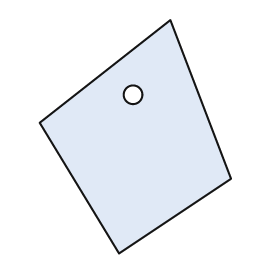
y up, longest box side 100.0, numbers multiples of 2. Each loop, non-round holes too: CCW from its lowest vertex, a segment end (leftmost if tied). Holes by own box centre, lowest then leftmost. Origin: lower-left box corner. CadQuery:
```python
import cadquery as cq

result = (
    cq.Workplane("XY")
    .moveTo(34.0, 0.0)
    .lineTo(82.0, 32.0)
    .lineTo(56.0, 100.0)
    .lineTo(0.0, 56.0)
    .close()
    .moveTo(40.0, 68.0)
    .circle(4.0)
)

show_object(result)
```